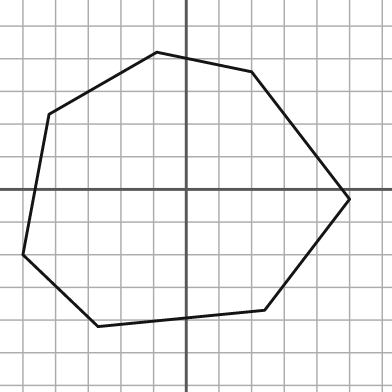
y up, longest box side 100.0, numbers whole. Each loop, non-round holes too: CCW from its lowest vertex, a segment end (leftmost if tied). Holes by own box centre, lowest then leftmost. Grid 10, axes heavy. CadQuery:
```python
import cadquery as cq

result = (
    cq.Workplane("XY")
    .moveTo(-27.0, -42.0)
    .lineTo(24.0, -37.0)
    .lineTo(50.0, -3.0)
    .lineTo(20.0, 36.0)
    .lineTo(-9.0, 42.0)
    .lineTo(-42.0, 23.0)
    .lineTo(-50.0, -20.0)
    .close()
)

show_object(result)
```